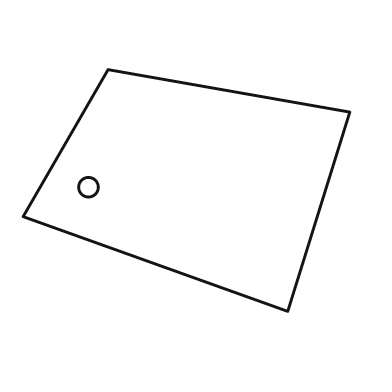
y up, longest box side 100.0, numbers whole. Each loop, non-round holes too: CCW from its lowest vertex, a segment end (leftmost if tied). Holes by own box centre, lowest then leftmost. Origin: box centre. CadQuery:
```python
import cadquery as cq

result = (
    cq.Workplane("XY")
    .moveTo(31.0, -37.0)
    .lineTo(50.0, 24.0)
    .lineTo(-24.0, 37.0)
    .lineTo(-50.0, -8.0)
    .close()
    .moveTo(-30.0, 1.0)
    .circle(3.0)
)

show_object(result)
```